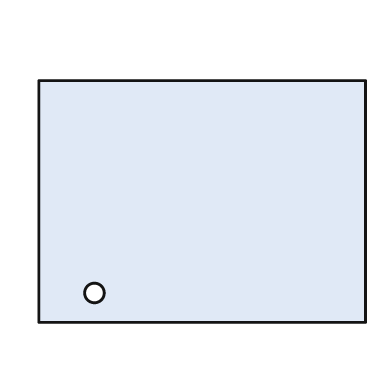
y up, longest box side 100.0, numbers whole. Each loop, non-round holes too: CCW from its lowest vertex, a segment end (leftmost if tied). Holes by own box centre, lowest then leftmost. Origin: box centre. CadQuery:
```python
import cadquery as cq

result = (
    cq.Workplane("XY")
    .moveTo(-50.0, -37.0)
    .lineTo(50.0, -37.0)
    .lineTo(50.0, 37.0)
    .lineTo(-50.0, 37.0)
    .close()
    .moveTo(-33.0, -28.0)
    .circle(3.0)
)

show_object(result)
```